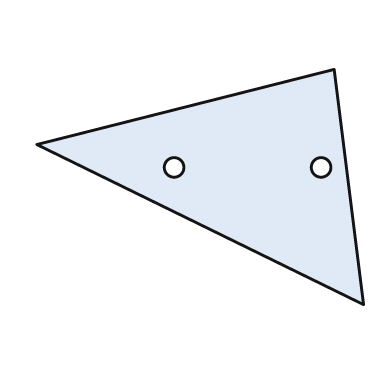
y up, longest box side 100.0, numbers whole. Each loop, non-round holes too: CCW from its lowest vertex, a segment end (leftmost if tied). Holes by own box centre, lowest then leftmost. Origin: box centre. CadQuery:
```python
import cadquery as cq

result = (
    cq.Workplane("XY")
    .moveTo(50.0, -36.0)
    .lineTo(41.0, 36.0)
    .lineTo(-50.0, 13.0)
    .close()
    .moveTo(-8.0, 6.0)
    .circle(3.0)
    .moveTo(37.0, 6.0)
    .circle(3.0)
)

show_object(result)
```